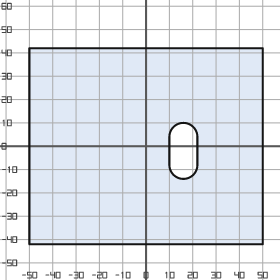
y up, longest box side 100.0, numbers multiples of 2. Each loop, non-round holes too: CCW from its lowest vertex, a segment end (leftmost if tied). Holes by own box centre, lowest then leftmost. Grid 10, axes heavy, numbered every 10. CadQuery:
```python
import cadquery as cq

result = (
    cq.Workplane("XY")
    .moveTo(-50.0, -42.0)
    .lineTo(50.0, -42.0)
    .lineTo(50.0, 42.0)
    .lineTo(-50.0, 42.0)
    .close()
    .moveTo(10.0, -8.0)
    .threePointArc((16.0, -14.0), (22.0, -8.0))
    .lineTo(22.0, 4.0)
    .threePointArc((16.0, 10.0), (10.0, 4.0))
    .close()
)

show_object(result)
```